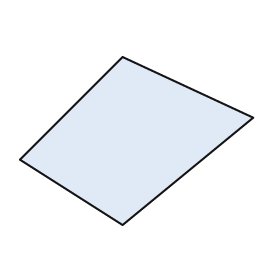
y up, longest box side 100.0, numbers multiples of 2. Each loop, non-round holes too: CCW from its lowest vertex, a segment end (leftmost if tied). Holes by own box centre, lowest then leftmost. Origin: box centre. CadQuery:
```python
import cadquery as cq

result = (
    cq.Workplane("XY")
    .moveTo(-6.0, -36.0)
    .lineTo(50.0, 10.0)
    .lineTo(-6.0, 36.0)
    .lineTo(-50.0, -8.0)
    .close()
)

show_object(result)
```